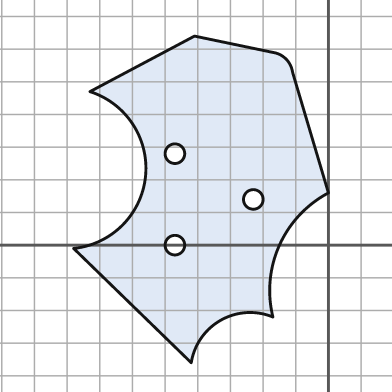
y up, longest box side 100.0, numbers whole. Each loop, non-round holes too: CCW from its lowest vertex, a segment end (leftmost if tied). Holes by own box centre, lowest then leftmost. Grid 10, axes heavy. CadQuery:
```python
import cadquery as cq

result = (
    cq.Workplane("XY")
    .moveTo(-42.0, -36.0)
    .threePointArc((-33.0, -23.0), (-17.0, -22.0))
    .threePointArc((-15.0, 0.0), (0.0, 16.0))
    .lineTo(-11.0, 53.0)
    .threePointArc((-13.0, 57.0), (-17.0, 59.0))
    .lineTo(-41.0, 64.0)
    .lineTo(-73.0, 47.0)
    .threePointArc((-56.0, 21.0), (-78.0, -1.0))
    .close()
    .moveTo(-47.0, 0.0)
    .circle(3.0)
    .moveTo(-23.0, 14.0)
    .circle(3.0)
    .moveTo(-47.0, 28.0)
    .circle(3.0)
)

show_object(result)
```